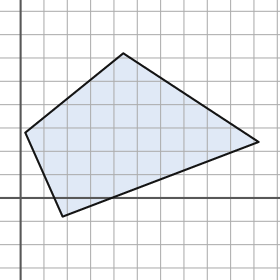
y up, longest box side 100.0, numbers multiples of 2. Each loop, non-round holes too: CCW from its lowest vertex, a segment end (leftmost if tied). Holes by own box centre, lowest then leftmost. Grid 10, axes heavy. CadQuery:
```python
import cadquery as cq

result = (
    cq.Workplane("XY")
    .moveTo(18.0, -8.0)
    .lineTo(102.0, 24.0)
    .lineTo(44.0, 62.0)
    .lineTo(2.0, 28.0)
    .close()
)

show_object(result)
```